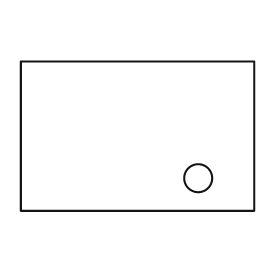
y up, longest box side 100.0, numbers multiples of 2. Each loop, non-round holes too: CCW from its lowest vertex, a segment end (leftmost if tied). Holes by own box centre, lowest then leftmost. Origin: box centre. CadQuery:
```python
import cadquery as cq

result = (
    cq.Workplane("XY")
    .moveTo(-50.0, -32.0)
    .lineTo(50.0, -32.0)
    .lineTo(50.0, 32.0)
    .lineTo(-50.0, 32.0)
    .close()
    .moveTo(26.0, -18.0)
    .circle(6.0)
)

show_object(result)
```